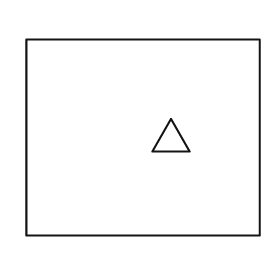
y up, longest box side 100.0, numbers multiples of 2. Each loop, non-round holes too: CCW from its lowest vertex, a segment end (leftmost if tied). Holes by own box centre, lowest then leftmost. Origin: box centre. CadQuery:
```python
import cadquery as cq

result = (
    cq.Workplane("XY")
    .moveTo(-50.0, -42.0)
    .lineTo(50.0, -42.0)
    .lineTo(50.0, 42.0)
    .lineTo(-50.0, 42.0)
    .close()
    .moveTo(4.0, -6.0)
    .lineTo(20.0, -6.0)
    .lineTo(12.0, 8.0)
    .close()
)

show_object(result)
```